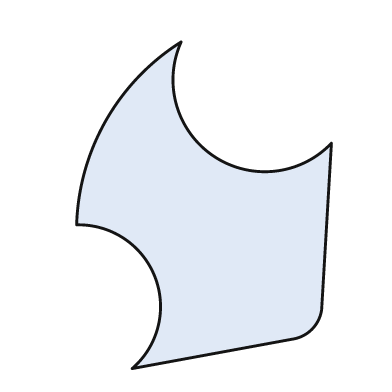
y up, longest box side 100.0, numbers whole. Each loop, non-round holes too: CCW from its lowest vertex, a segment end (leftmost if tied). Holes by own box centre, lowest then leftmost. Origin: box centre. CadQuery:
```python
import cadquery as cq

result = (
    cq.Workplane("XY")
    .moveTo(-22.0, -50.0)
    .lineTo(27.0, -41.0)
    .threePointArc((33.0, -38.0), (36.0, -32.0))
    .lineTo(39.0, 19.0)
    .threePointArc((3.0, 15.0), (-7.0, 50.0))
    .threePointArc((-30.0, 26.0), (-39.0, -6.0))
    .threePointArc((-15.0, -22.0), (-22.0, -50.0))
    .close()
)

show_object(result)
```